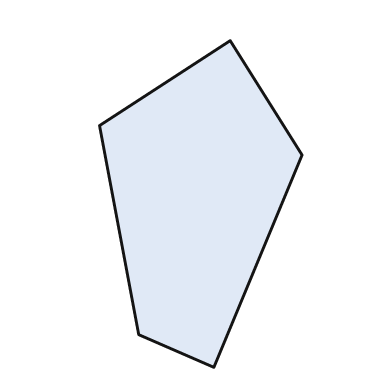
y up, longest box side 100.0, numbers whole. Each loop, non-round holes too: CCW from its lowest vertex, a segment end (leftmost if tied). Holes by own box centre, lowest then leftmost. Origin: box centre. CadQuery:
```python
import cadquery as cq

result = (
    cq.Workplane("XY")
    .moveTo(4.0, -50.0)
    .lineTo(31.0, 15.0)
    .lineTo(9.0, 50.0)
    .lineTo(-31.0, 24.0)
    .lineTo(-19.0, -40.0)
    .close()
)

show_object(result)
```